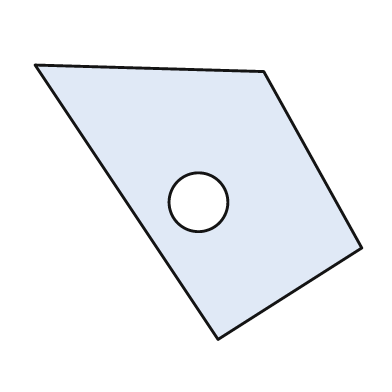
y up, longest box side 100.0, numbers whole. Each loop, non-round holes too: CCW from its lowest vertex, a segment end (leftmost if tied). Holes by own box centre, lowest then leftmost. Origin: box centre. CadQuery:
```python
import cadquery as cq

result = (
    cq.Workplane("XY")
    .moveTo(6.0, -42.0)
    .lineTo(50.0, -14.0)
    .lineTo(20.0, 40.0)
    .lineTo(-50.0, 42.0)
    .close()
    .moveTo(0.0, 0.0)
    .circle(9.0)
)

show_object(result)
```